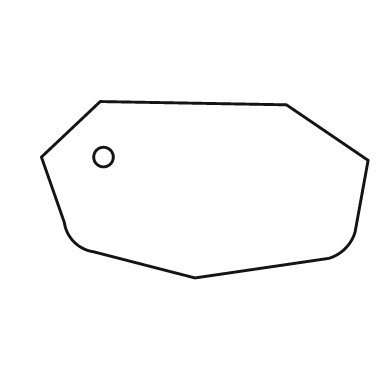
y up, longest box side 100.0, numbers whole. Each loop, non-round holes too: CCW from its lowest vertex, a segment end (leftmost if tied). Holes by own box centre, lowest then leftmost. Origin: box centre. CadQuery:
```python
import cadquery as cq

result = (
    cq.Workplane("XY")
    .moveTo(-3.0, -27.0)
    .lineTo(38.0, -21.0)
    .threePointArc((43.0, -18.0), (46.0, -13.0))
    .lineTo(50.0, 9.0)
    .lineTo(25.0, 26.0)
    .lineTo(-32.0, 27.0)
    .lineTo(-50.0, 10.0)
    .lineTo(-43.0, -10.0)
    .threePointArc((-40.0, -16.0), (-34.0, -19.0))
    .close()
    .moveTo(-31.0, 10.0)
    .circle(3.0)
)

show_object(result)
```